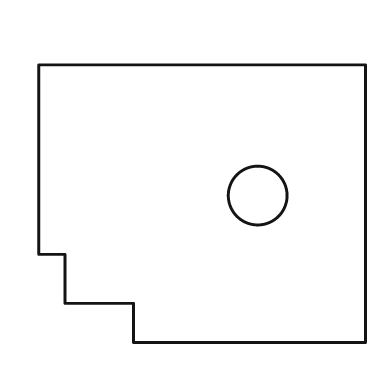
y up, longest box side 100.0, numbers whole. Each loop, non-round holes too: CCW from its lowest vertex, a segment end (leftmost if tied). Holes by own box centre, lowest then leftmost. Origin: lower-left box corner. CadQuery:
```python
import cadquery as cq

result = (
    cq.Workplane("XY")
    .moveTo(29.0, 0.0)
    .lineTo(100.0, 0.0)
    .lineTo(100.0, 85.0)
    .lineTo(0.0, 85.0)
    .lineTo(0.0, 27.0)
    .lineTo(8.0, 27.0)
    .lineTo(8.0, 12.0)
    .lineTo(29.0, 12.0)
    .close()
    .moveTo(67.0, 45.0)
    .circle(9.0)
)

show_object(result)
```